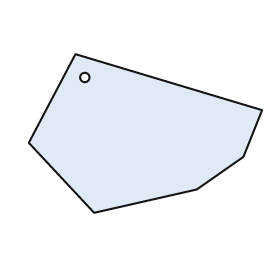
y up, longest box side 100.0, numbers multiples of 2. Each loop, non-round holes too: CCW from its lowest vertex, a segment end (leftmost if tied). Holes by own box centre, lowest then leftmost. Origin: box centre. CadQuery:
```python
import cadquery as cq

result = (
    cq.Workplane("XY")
    .moveTo(-22.0, -34.0)
    .lineTo(22.0, -24.0)
    .lineTo(42.0, -10.0)
    .lineTo(50.0, 10.0)
    .lineTo(-30.0, 34.0)
    .lineTo(-50.0, -4.0)
    .close()
    .moveTo(-26.0, 24.0)
    .circle(2.0)
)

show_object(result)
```